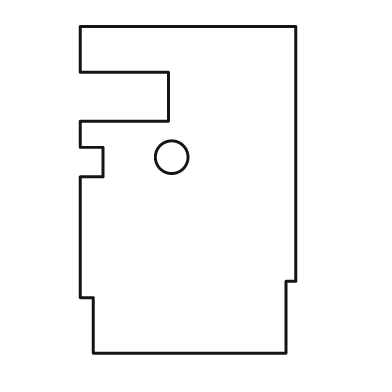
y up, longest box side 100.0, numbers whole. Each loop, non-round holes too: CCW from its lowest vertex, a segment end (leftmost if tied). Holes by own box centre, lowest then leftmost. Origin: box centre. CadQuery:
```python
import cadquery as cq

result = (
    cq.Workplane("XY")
    .moveTo(-29.0, -50.0)
    .lineTo(30.0, -50.0)
    .lineTo(30.0, -28.0)
    .lineTo(33.0, -28.0)
    .lineTo(33.0, 50.0)
    .lineTo(-33.0, 50.0)
    .lineTo(-33.0, 36.0)
    .lineTo(-6.0, 36.0)
    .lineTo(-6.0, 21.0)
    .lineTo(-33.0, 21.0)
    .lineTo(-33.0, 13.0)
    .lineTo(-26.0, 13.0)
    .lineTo(-26.0, 4.0)
    .lineTo(-33.0, 4.0)
    .lineTo(-33.0, -33.0)
    .lineTo(-29.0, -33.0)
    .close()
    .moveTo(-5.0, 10.0)
    .circle(5.0)
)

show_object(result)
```